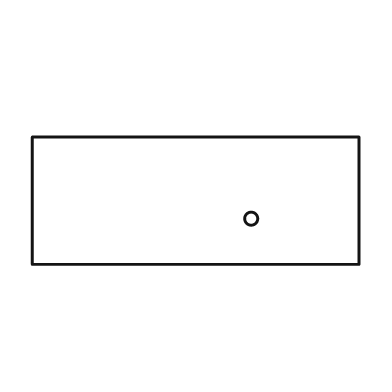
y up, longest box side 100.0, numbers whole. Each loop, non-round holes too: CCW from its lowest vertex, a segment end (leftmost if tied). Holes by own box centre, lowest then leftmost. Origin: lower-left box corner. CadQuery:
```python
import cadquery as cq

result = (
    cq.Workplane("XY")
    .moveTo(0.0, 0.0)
    .lineTo(100.0, 0.0)
    .lineTo(100.0, 39.0)
    .lineTo(0.0, 39.0)
    .close()
    .moveTo(67.0, 14.0)
    .circle(2.0)
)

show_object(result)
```